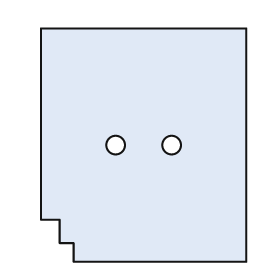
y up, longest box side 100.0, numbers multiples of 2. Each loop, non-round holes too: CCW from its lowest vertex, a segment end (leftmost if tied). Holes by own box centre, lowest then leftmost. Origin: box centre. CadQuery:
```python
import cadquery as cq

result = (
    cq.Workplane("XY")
    .moveTo(-30.0, -50.0)
    .lineTo(44.0, -50.0)
    .lineTo(44.0, 50.0)
    .lineTo(-44.0, 50.0)
    .lineTo(-44.0, -32.0)
    .lineTo(-36.0, -32.0)
    .lineTo(-36.0, -42.0)
    .lineTo(-30.0, -42.0)
    .close()
    .moveTo(-12.0, 0.0)
    .circle(4.0)
    .moveTo(12.0, 0.0)
    .circle(4.0)
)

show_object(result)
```